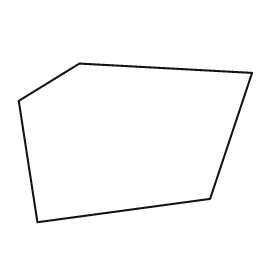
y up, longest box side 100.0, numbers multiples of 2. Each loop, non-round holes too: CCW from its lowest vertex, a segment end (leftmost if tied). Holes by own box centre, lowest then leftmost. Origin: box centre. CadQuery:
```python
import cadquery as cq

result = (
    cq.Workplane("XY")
    .moveTo(-42.0, -34.0)
    .lineTo(32.0, -24.0)
    .lineTo(50.0, 30.0)
    .lineTo(-24.0, 34.0)
    .lineTo(-50.0, 18.0)
    .close()
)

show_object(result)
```